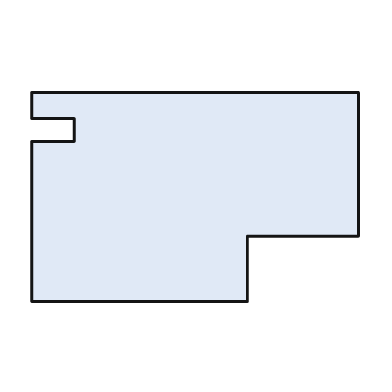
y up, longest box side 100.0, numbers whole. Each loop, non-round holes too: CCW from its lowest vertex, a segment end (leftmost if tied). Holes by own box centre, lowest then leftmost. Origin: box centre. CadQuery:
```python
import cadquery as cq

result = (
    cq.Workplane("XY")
    .moveTo(-50.0, -32.0)
    .lineTo(16.0, -32.0)
    .lineTo(16.0, -12.0)
    .lineTo(50.0, -12.0)
    .lineTo(50.0, 32.0)
    .lineTo(-50.0, 32.0)
    .lineTo(-50.0, 24.0)
    .lineTo(-37.0, 24.0)
    .lineTo(-37.0, 17.0)
    .lineTo(-50.0, 17.0)
    .close()
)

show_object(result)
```